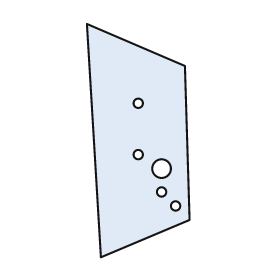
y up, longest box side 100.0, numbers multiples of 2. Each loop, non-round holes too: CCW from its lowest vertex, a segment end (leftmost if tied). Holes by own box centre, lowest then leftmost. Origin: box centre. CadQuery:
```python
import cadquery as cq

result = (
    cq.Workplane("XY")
    .moveTo(-16.0, -50.0)
    .lineTo(22.0, -34.0)
    .lineTo(20.0, 32.0)
    .lineTo(-22.0, 50.0)
    .close()
    .moveTo(16.0, -28.0)
    .circle(2.0)
    .moveTo(10.0, -22.0)
    .circle(2.0)
    .moveTo(10.0, -12.0)
    .circle(4.0)
    .moveTo(0.0, -6.0)
    .circle(2.0)
    .moveTo(0.0, 16.0)
    .circle(2.0)
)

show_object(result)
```